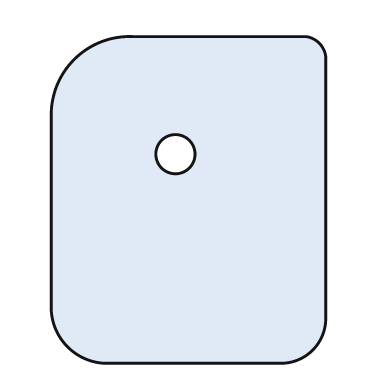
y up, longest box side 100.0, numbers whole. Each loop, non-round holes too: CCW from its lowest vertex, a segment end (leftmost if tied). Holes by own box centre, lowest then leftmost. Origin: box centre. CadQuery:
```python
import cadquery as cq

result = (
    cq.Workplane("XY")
    .moveTo(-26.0, -50.0)
    .lineTo(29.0, -50.0)
    .threePointArc((38.0, -46.0), (42.0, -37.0))
    .lineTo(42.0, 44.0)
    .threePointArc((40.0, 48.0), (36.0, 50.0))
    .lineTo(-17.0, 50.0)
    .threePointArc((-35.0, 43.0), (-42.0, 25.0))
    .lineTo(-42.0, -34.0)
    .threePointArc((-37.0, -45.0), (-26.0, -50.0))
    .close()
    .moveTo(-4.0, 14.0)
    .circle(6.0)
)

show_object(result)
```